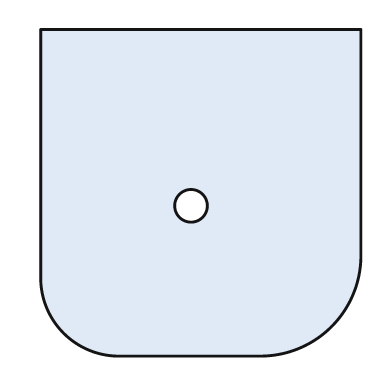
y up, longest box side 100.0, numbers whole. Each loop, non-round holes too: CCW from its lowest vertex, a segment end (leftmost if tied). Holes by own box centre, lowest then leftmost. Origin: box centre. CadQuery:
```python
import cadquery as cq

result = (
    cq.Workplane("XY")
    .moveTo(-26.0, -50.0)
    .lineTo(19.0, -50.0)
    .threePointArc((40.0, -41.0), (49.0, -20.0))
    .lineTo(49.0, 50.0)
    .lineTo(-49.0, 50.0)
    .lineTo(-49.0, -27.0)
    .threePointArc((-42.0, -43.0), (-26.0, -50.0))
    .close()
    .moveTo(-3.0, -4.0)
    .circle(5.0)
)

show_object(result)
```